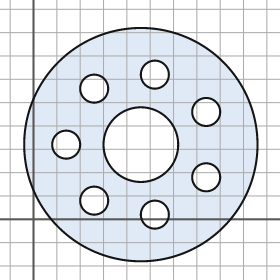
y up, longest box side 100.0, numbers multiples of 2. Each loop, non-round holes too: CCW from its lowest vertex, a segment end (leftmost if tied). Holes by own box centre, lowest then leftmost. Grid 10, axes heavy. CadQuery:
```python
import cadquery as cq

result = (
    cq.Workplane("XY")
    .moveTo(46.0, 32.0)
    .circle(50.0)
    .moveTo(52.0, 2.0)
    .circle(6.0)
    .moveTo(26.0, 8.0)
    .circle(6.0)
    .moveTo(74.0, 18.0)
    .circle(6.0)
    .moveTo(14.0, 32.0)
    .circle(6.0)
    .moveTo(46.0, 32.0)
    .circle(16.0)
    .moveTo(74.0, 46.0)
    .circle(6.0)
    .moveTo(26.0, 56.0)
    .circle(6.0)
    .moveTo(52.0, 62.0)
    .circle(6.0)
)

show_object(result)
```